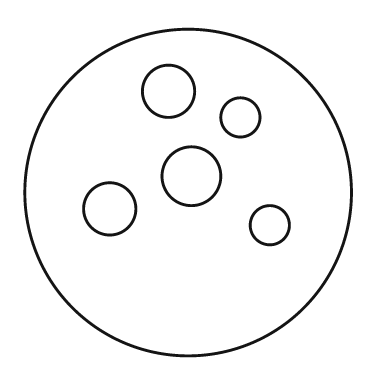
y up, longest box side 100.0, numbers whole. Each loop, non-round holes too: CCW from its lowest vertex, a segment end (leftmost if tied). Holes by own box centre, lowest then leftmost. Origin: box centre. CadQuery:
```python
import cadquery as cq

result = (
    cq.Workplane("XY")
    .moveTo(0.0, 0.0)
    .circle(50.0)
    .moveTo(25.0, -10.0)
    .circle(6.0)
    .moveTo(-24.0, -5.0)
    .circle(8.0)
    .moveTo(1.0, 5.0)
    .circle(9.0)
    .moveTo(16.0, 23.0)
    .circle(6.0)
    .moveTo(-6.0, 31.0)
    .circle(8.0)
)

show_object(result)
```